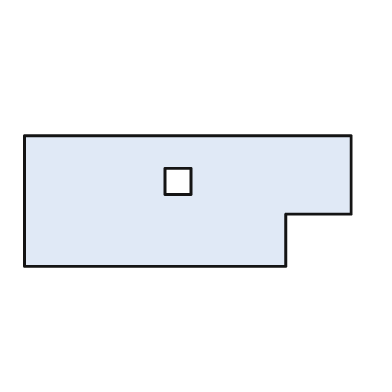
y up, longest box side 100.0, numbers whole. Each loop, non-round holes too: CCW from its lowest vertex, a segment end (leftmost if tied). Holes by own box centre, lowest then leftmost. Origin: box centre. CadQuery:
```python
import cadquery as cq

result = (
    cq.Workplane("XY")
    .moveTo(-50.0, -20.0)
    .lineTo(30.0, -20.0)
    .lineTo(30.0, -4.0)
    .lineTo(50.0, -4.0)
    .lineTo(50.0, 20.0)
    .lineTo(-50.0, 20.0)
    .close()
    .moveTo(-7.0, 2.0)
    .lineTo(1.0, 2.0)
    .lineTo(1.0, 10.0)
    .lineTo(-7.0, 10.0)
    .close()
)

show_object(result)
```